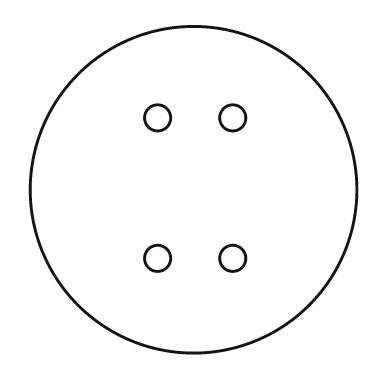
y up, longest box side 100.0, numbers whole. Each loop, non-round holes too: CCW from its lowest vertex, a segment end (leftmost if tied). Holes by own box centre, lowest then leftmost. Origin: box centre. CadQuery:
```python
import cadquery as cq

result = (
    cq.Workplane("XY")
    .moveTo(0.0, 0.0)
    .circle(50.0)
    .moveTo(-11.0, -21.0)
    .circle(4.0)
    .moveTo(12.0, -21.0)
    .circle(4.0)
    .moveTo(-11.0, 22.0)
    .circle(4.0)
    .moveTo(12.0, 22.0)
    .circle(4.0)
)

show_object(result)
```